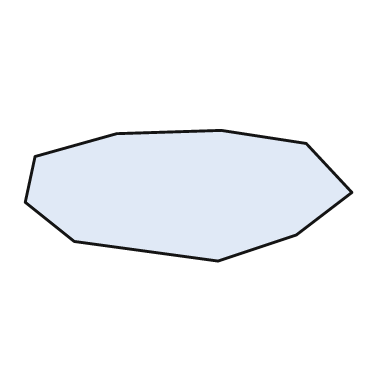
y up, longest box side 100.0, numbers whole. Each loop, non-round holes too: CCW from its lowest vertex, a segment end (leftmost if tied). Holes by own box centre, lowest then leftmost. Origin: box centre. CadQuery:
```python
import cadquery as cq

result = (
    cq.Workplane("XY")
    .moveTo(9.0, -20.0)
    .lineTo(33.0, -12.0)
    .lineTo(50.0, 1.0)
    .lineTo(36.0, 16.0)
    .lineTo(10.0, 20.0)
    .lineTo(-22.0, 19.0)
    .lineTo(-47.0, 12.0)
    .lineTo(-50.0, -2.0)
    .lineTo(-35.0, -14.0)
    .close()
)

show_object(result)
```